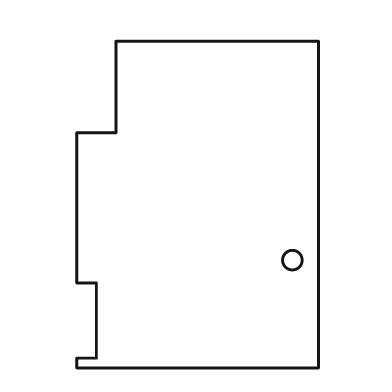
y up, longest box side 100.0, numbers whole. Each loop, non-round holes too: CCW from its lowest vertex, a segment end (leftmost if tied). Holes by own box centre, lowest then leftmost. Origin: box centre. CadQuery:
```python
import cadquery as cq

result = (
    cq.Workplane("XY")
    .moveTo(-37.0, -50.0)
    .lineTo(37.0, -50.0)
    .lineTo(37.0, 50.0)
    .lineTo(-25.0, 50.0)
    .lineTo(-25.0, 22.0)
    .lineTo(-37.0, 22.0)
    .lineTo(-37.0, -24.0)
    .lineTo(-31.0, -24.0)
    .lineTo(-31.0, -47.0)
    .lineTo(-37.0, -47.0)
    .close()
    .moveTo(29.0, -17.0)
    .circle(3.0)
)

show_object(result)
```